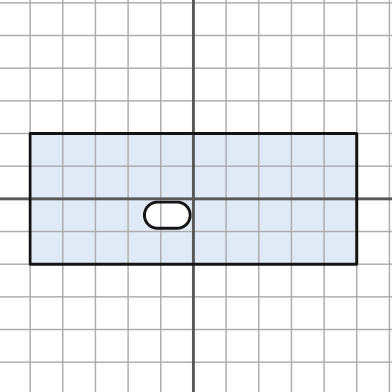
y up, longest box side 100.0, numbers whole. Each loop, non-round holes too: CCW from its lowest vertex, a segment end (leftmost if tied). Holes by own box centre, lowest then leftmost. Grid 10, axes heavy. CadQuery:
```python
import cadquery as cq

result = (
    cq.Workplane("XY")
    .moveTo(-50.0, -20.0)
    .lineTo(50.0, -20.0)
    .lineTo(50.0, 20.0)
    .lineTo(-50.0, 20.0)
    .close()
    .moveTo(-11.0, -9.0)
    .lineTo(-5.0, -9.0)
    .threePointArc((-1.0, -5.0), (-5.0, -1.0))
    .lineTo(-11.0, -1.0)
    .threePointArc((-15.0, -5.0), (-11.0, -9.0))
    .close()
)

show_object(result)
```